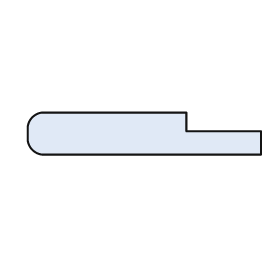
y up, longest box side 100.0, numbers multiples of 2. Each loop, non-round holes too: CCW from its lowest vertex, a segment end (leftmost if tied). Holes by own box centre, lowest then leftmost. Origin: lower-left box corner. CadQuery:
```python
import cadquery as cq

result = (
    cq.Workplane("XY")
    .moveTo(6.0, 0.0)
    .lineTo(100.0, 0.0)
    .lineTo(100.0, 10.0)
    .lineTo(68.0, 10.0)
    .lineTo(68.0, 18.0)
    .lineTo(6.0, 18.0)
    .threePointArc((2.0, 16.0), (0.0, 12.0))
    .lineTo(0.0, 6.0)
    .threePointArc((2.0, 2.0), (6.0, 0.0))
    .close()
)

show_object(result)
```